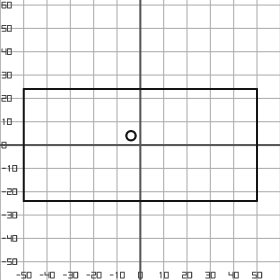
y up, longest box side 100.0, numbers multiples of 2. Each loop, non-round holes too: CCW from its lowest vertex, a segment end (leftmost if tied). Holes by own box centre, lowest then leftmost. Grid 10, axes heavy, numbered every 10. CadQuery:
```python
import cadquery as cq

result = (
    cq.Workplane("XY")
    .moveTo(-50.0, -24.0)
    .lineTo(50.0, -24.0)
    .lineTo(50.0, 24.0)
    .lineTo(-50.0, 24.0)
    .close()
    .moveTo(-4.0, 4.0)
    .circle(2.0)
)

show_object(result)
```